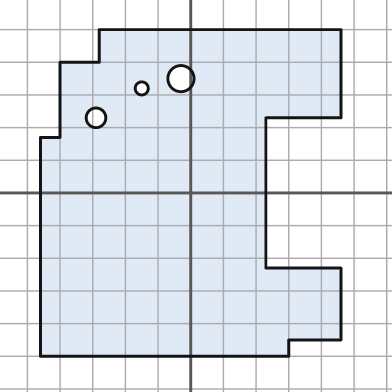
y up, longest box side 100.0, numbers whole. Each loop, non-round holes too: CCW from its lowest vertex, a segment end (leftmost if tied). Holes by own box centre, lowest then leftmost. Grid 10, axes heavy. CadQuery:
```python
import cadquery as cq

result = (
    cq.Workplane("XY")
    .moveTo(-46.0, -50.0)
    .lineTo(30.0, -50.0)
    .lineTo(30.0, -45.0)
    .lineTo(46.0, -45.0)
    .lineTo(46.0, -23.0)
    .lineTo(23.0, -23.0)
    .lineTo(23.0, 23.0)
    .lineTo(46.0, 23.0)
    .lineTo(46.0, 50.0)
    .lineTo(-28.0, 50.0)
    .lineTo(-28.0, 40.0)
    .lineTo(-40.0, 40.0)
    .lineTo(-40.0, 17.0)
    .lineTo(-46.0, 17.0)
    .close()
    .moveTo(-29.0, 23.0)
    .circle(3.0)
    .moveTo(-15.0, 32.0)
    .circle(2.0)
    .moveTo(-3.0, 35.0)
    .circle(4.0)
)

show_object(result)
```